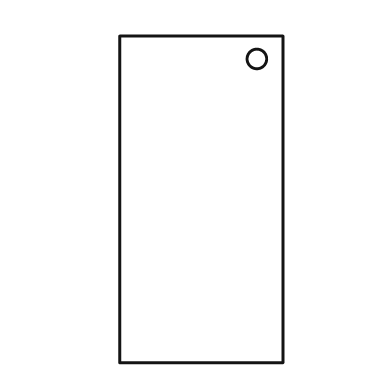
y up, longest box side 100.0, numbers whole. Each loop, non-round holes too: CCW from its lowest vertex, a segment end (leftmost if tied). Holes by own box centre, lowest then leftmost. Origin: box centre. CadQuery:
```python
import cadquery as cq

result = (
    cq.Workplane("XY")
    .moveTo(-25.0, -50.0)
    .lineTo(25.0, -50.0)
    .lineTo(25.0, 50.0)
    .lineTo(-25.0, 50.0)
    .close()
    .moveTo(17.0, 43.0)
    .circle(3.0)
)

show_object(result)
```